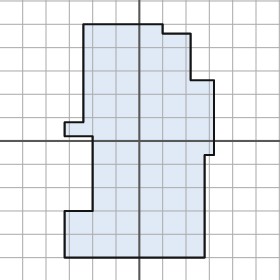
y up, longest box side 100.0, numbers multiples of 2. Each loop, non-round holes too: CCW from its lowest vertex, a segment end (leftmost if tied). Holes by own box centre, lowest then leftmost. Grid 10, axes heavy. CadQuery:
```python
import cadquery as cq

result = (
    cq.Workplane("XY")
    .moveTo(-32.0, -50.0)
    .lineTo(28.0, -50.0)
    .lineTo(28.0, -6.0)
    .lineTo(32.0, -6.0)
    .lineTo(32.0, 26.0)
    .lineTo(22.0, 26.0)
    .lineTo(22.0, 46.0)
    .lineTo(10.0, 46.0)
    .lineTo(10.0, 50.0)
    .lineTo(-24.0, 50.0)
    .lineTo(-24.0, 8.0)
    .lineTo(-32.0, 8.0)
    .lineTo(-32.0, 2.0)
    .lineTo(-20.0, 2.0)
    .lineTo(-20.0, -30.0)
    .lineTo(-32.0, -30.0)
    .close()
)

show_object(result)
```